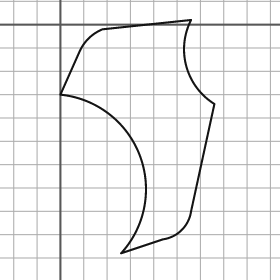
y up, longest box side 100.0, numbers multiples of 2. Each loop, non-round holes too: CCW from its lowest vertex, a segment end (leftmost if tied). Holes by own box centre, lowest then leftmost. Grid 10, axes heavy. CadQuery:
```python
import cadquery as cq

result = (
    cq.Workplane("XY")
    .moveTo(26.0, -98.0)
    .lineTo(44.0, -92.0)
    .threePointArc((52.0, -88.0), (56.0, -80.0))
    .lineTo(66.0, -34.0)
    .threePointArc((54.0, -18.0), (56.0, 2.0))
    .lineTo(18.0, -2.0)
    .threePointArc((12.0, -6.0), (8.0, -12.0))
    .lineTo(0.0, -30.0)
    .threePointArc((34.0, -56.0), (26.0, -98.0))
    .close()
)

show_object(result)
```